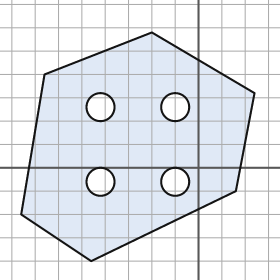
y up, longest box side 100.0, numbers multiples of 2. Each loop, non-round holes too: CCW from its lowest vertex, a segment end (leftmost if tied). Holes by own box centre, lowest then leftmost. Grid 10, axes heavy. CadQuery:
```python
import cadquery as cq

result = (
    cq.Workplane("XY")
    .moveTo(-46.0, -40.0)
    .lineTo(16.0, -10.0)
    .lineTo(24.0, 32.0)
    .lineTo(-20.0, 58.0)
    .lineTo(-66.0, 40.0)
    .lineTo(-76.0, -20.0)
    .close()
    .moveTo(-42.0, -6.0)
    .circle(6.0)
    .moveTo(-10.0, -6.0)
    .circle(6.0)
    .moveTo(-42.0, 26.0)
    .circle(6.0)
    .moveTo(-10.0, 26.0)
    .circle(6.0)
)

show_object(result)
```